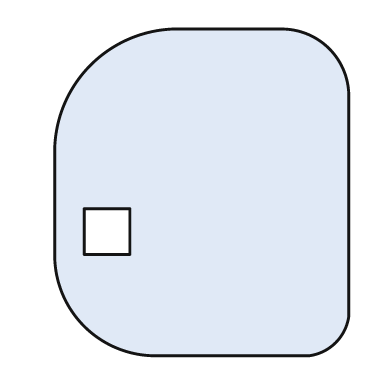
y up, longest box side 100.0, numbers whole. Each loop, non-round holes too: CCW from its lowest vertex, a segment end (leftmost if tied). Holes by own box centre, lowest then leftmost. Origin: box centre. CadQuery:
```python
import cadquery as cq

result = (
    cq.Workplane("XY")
    .moveTo(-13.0, -50.0)
    .lineTo(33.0, -50.0)
    .threePointArc((41.0, -46.0), (45.0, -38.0))
    .lineTo(45.0, 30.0)
    .threePointArc((39.0, 44.0), (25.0, 50.0))
    .lineTo(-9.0, 50.0)
    .threePointArc((-34.0, 39.0), (-45.0, 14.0))
    .lineTo(-45.0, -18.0)
    .threePointArc((-36.0, -41.0), (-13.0, -50.0))
    .close()
    .moveTo(-36.0, -19.0)
    .lineTo(-22.0, -19.0)
    .lineTo(-22.0, -5.0)
    .lineTo(-36.0, -5.0)
    .close()
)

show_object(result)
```